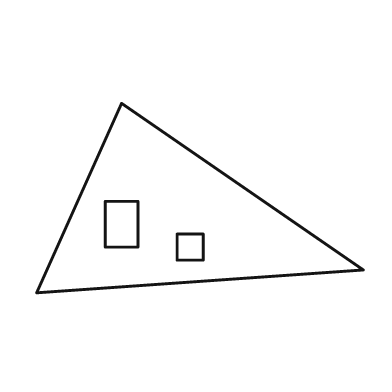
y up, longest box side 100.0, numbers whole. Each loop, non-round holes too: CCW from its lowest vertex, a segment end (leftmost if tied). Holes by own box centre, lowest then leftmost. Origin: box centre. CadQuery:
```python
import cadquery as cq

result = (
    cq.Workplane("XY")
    .moveTo(-50.0, -29.0)
    .lineTo(50.0, -22.0)
    .lineTo(-24.0, 29.0)
    .close()
    .moveTo(-7.0, -19.0)
    .lineTo(1.0, -19.0)
    .lineTo(1.0, -11.0)
    .lineTo(-7.0, -11.0)
    .close()
    .moveTo(-29.0, -15.0)
    .lineTo(-19.0, -15.0)
    .lineTo(-19.0, -1.0)
    .lineTo(-29.0, -1.0)
    .close()
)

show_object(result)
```